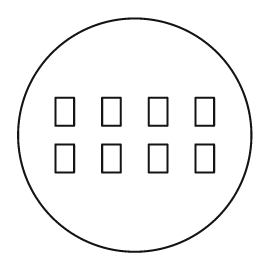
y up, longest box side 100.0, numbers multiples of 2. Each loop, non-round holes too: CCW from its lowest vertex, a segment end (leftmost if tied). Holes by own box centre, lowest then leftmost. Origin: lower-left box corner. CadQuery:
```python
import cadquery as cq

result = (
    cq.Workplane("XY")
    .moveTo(50.0, 50.0)
    .circle(50.0)
    .moveTo(16.0, 34.0)
    .lineTo(24.0, 34.0)
    .lineTo(24.0, 46.0)
    .lineTo(16.0, 46.0)
    .close()
    .moveTo(36.0, 34.0)
    .lineTo(44.0, 34.0)
    .lineTo(44.0, 46.0)
    .lineTo(36.0, 46.0)
    .close()
    .moveTo(56.0, 34.0)
    .lineTo(64.0, 34.0)
    .lineTo(64.0, 46.0)
    .lineTo(56.0, 46.0)
    .close()
    .moveTo(76.0, 34.0)
    .lineTo(84.0, 34.0)
    .lineTo(84.0, 46.0)
    .lineTo(76.0, 46.0)
    .close()
    .moveTo(16.0, 54.0)
    .lineTo(24.0, 54.0)
    .lineTo(24.0, 66.0)
    .lineTo(16.0, 66.0)
    .close()
    .moveTo(36.0, 54.0)
    .lineTo(44.0, 54.0)
    .lineTo(44.0, 66.0)
    .lineTo(36.0, 66.0)
    .close()
    .moveTo(56.0, 54.0)
    .lineTo(64.0, 54.0)
    .lineTo(64.0, 66.0)
    .lineTo(56.0, 66.0)
    .close()
    .moveTo(76.0, 54.0)
    .lineTo(84.0, 54.0)
    .lineTo(84.0, 66.0)
    .lineTo(76.0, 66.0)
    .close()
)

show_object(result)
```